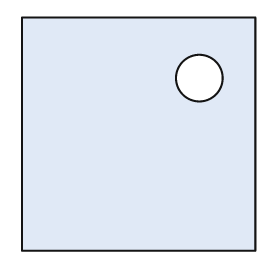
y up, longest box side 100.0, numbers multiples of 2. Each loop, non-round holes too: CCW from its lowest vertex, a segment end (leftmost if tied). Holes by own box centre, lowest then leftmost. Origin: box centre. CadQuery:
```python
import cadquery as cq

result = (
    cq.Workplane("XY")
    .moveTo(-50.0, -50.0)
    .lineTo(50.0, -50.0)
    .lineTo(50.0, 50.0)
    .lineTo(-50.0, 50.0)
    .close()
    .moveTo(26.0, 24.0)
    .circle(10.0)
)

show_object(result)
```